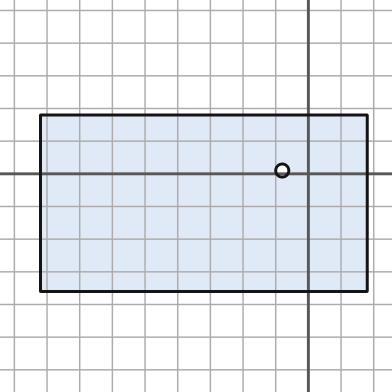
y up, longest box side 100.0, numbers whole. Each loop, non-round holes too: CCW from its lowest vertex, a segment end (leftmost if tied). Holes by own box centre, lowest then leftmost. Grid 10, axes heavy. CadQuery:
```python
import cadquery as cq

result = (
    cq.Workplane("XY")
    .moveTo(-82.0, -36.0)
    .lineTo(18.0, -36.0)
    .lineTo(18.0, 18.0)
    .lineTo(-82.0, 18.0)
    .close()
    .moveTo(-8.0, 1.0)
    .circle(2.0)
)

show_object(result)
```